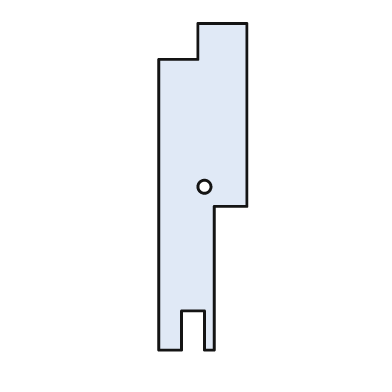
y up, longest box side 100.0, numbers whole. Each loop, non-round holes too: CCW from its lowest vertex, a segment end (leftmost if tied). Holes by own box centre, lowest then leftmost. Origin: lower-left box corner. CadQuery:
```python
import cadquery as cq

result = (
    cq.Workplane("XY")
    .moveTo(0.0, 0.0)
    .lineTo(7.0, 0.0)
    .lineTo(7.0, 12.0)
    .lineTo(14.0, 12.0)
    .lineTo(14.0, 0.0)
    .lineTo(17.0, 0.0)
    .lineTo(17.0, 44.0)
    .lineTo(27.0, 44.0)
    .lineTo(27.0, 100.0)
    .lineTo(12.0, 100.0)
    .lineTo(12.0, 89.0)
    .lineTo(0.0, 89.0)
    .close()
    .moveTo(14.0, 50.0)
    .circle(2.0)
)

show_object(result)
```